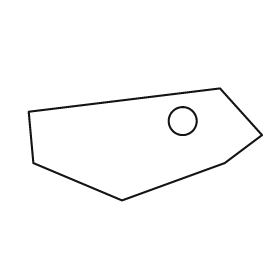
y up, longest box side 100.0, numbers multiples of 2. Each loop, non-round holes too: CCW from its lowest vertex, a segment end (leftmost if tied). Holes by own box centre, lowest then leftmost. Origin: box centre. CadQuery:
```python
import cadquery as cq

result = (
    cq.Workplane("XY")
    .moveTo(-10.0, -24.0)
    .lineTo(34.0, -8.0)
    .lineTo(50.0, 4.0)
    .lineTo(32.0, 24.0)
    .lineTo(-50.0, 14.0)
    .lineTo(-48.0, -8.0)
    .close()
    .moveTo(16.0, 10.0)
    .circle(6.0)
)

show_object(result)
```